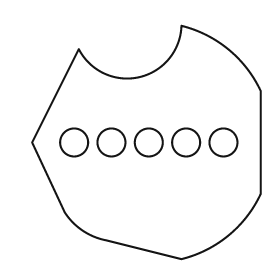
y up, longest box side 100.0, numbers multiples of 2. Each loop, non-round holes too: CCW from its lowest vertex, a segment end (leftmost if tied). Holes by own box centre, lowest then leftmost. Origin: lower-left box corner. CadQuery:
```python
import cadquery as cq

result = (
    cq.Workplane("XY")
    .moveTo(64.0, 0.0)
    .threePointArc((84.0, 10.0), (98.0, 28.0))
    .lineTo(98.0, 72.0)
    .threePointArc((84.0, 90.0), (64.0, 100.0))
    .threePointArc((46.0, 78.0), (20.0, 90.0))
    .lineTo(0.0, 50.0)
    .lineTo(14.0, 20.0)
    .threePointArc((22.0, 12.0), (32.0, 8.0))
    .close()
    .moveTo(18.0, 50.0)
    .circle(6.0)
    .moveTo(34.0, 50.0)
    .circle(6.0)
    .moveTo(50.0, 50.0)
    .circle(6.0)
    .moveTo(66.0, 50.0)
    .circle(6.0)
    .moveTo(82.0, 50.0)
    .circle(6.0)
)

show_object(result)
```